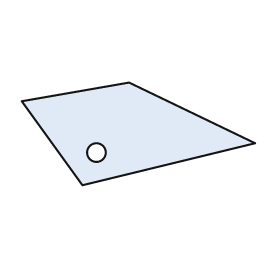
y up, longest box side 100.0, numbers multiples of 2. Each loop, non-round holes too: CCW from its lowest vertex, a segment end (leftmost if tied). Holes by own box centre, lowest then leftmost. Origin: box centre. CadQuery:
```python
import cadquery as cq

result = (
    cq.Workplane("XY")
    .moveTo(-24.0, -22.0)
    .lineTo(50.0, -4.0)
    .lineTo(-4.0, 22.0)
    .lineTo(-50.0, 14.0)
    .close()
    .moveTo(-18.0, -8.0)
    .circle(4.0)
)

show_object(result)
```